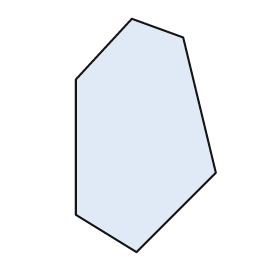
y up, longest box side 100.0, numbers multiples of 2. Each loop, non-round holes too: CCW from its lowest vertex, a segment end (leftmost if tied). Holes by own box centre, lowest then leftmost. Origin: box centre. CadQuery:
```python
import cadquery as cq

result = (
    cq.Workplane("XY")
    .moveTo(-4.0, -50.0)
    .lineTo(30.0, -16.0)
    .lineTo(16.0, 42.0)
    .lineTo(-6.0, 50.0)
    .lineTo(-30.0, 24.0)
    .lineTo(-30.0, -34.0)
    .close()
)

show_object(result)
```